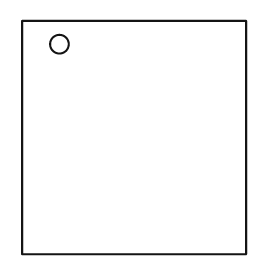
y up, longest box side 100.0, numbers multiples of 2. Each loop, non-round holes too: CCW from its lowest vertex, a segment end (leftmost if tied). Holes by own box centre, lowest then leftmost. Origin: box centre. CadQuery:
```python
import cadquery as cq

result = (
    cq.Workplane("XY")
    .moveTo(-48.0, -50.0)
    .lineTo(48.0, -50.0)
    .lineTo(48.0, 50.0)
    .lineTo(-48.0, 50.0)
    .close()
    .moveTo(-32.0, 40.0)
    .circle(4.0)
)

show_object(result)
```